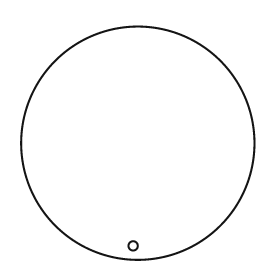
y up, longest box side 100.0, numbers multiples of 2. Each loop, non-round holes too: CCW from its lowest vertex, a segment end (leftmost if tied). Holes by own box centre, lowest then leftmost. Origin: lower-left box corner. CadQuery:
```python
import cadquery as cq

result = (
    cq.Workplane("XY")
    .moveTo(50.0, 50.0)
    .circle(50.0)
    .moveTo(48.0, 6.0)
    .circle(2.0)
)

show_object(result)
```